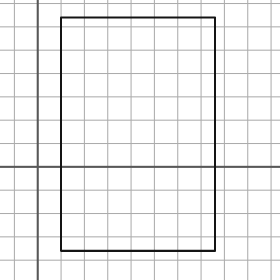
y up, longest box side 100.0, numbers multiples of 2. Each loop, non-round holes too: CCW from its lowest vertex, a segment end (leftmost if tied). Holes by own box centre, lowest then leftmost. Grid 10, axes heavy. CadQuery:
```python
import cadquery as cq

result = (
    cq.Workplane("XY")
    .moveTo(10.0, -36.0)
    .lineTo(76.0, -36.0)
    .lineTo(76.0, 64.0)
    .lineTo(10.0, 64.0)
    .close()
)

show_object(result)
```